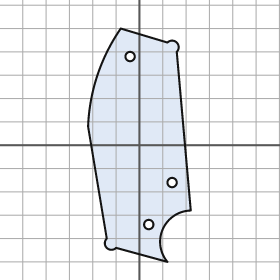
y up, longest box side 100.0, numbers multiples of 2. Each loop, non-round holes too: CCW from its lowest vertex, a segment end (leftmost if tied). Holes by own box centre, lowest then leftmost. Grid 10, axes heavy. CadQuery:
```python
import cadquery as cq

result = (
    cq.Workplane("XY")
    .moveTo(12.0, -50.0)
    .threePointArc((10.0, -36.0), (22.0, -28.0))
    .lineTo(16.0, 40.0)
    .threePointArc((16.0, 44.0), (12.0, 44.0))
    .lineTo(-8.0, 50.0)
    .threePointArc((-18.0, 30.0), (-22.0, 8.0))
    .lineTo(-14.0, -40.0)
    .threePointArc((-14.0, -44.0), (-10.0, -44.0))
    .close()
    .moveTo(4.0, -34.0)
    .circle(2.0)
    .moveTo(14.0, -16.0)
    .circle(2.0)
    .moveTo(-4.0, 38.0)
    .circle(2.0)
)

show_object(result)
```